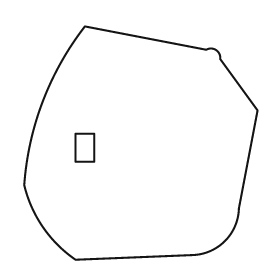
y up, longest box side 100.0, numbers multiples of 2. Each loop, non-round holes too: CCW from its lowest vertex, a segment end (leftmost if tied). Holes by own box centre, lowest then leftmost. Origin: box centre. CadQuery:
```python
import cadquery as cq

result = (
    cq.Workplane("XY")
    .moveTo(-28.0, -50.0)
    .lineTo(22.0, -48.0)
    .threePointArc((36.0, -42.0), (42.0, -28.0))
    .lineTo(50.0, 14.0)
    .lineTo(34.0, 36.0)
    .threePointArc((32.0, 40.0), (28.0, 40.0))
    .lineTo(-24.0, 50.0)
    .threePointArc((-42.0, 18.0), (-50.0, -18.0))
    .threePointArc((-42.0, -36.0), (-28.0, -50.0))
    .close()
    .moveTo(-28.0, -8.0)
    .lineTo(-20.0, -8.0)
    .lineTo(-20.0, 4.0)
    .lineTo(-28.0, 4.0)
    .close()
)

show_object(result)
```